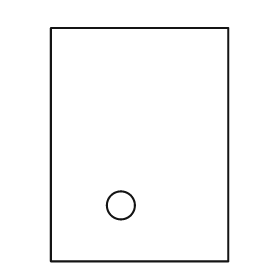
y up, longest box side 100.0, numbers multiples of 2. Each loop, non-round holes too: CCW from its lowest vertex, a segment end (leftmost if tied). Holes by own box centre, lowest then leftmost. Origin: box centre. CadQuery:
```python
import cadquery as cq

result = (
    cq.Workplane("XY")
    .moveTo(-38.0, -50.0)
    .lineTo(38.0, -50.0)
    .lineTo(38.0, 50.0)
    .lineTo(-38.0, 50.0)
    .close()
    .moveTo(-8.0, -26.0)
    .circle(6.0)
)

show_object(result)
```